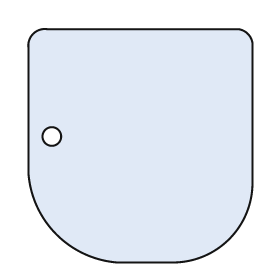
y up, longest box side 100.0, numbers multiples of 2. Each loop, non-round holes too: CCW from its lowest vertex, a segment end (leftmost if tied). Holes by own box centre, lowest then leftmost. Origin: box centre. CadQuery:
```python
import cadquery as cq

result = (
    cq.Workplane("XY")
    .moveTo(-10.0, -50.0)
    .lineTo(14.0, -50.0)
    .threePointArc((38.0, -40.0), (48.0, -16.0))
    .lineTo(48.0, 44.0)
    .threePointArc((46.0, 48.0), (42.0, 50.0))
    .lineTo(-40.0, 50.0)
    .threePointArc((-46.0, 48.0), (-48.0, 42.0))
    .lineTo(-48.0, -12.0)
    .threePointArc((-36.0, -38.0), (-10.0, -50.0))
    .close()
    .moveTo(-38.0, 4.0)
    .circle(4.0)
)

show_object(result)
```